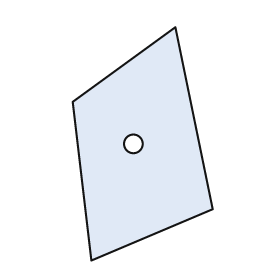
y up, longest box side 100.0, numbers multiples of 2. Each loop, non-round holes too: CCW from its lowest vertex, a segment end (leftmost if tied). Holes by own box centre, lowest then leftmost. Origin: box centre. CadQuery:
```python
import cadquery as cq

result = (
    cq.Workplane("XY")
    .moveTo(-22.0, -50.0)
    .lineTo(30.0, -28.0)
    .lineTo(14.0, 50.0)
    .lineTo(-30.0, 18.0)
    .close()
    .moveTo(-4.0, 0.0)
    .circle(4.0)
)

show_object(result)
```